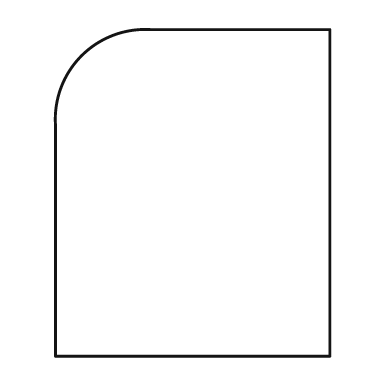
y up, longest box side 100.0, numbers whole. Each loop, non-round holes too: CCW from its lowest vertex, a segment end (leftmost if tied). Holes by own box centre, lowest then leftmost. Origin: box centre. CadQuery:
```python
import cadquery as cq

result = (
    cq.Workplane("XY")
    .moveTo(-42.0, -50.0)
    .lineTo(42.0, -50.0)
    .lineTo(42.0, 50.0)
    .lineTo(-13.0, 50.0)
    .threePointArc((-34.0, 42.0), (-42.0, 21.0))
    .close()
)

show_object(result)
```